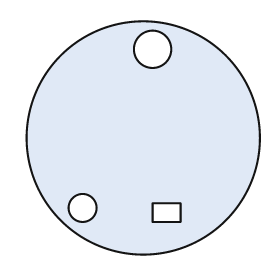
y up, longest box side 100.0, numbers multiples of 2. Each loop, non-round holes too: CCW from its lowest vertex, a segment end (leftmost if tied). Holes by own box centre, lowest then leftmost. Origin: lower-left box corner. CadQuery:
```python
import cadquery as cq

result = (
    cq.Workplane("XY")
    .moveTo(50.0, 50.0)
    .circle(50.0)
    .moveTo(54.0, 14.0)
    .lineTo(66.0, 14.0)
    .lineTo(66.0, 22.0)
    .lineTo(54.0, 22.0)
    .close()
    .moveTo(24.0, 20.0)
    .circle(6.0)
    .moveTo(54.0, 88.0)
    .circle(8.0)
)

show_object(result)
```